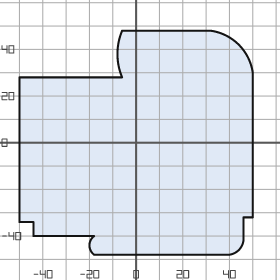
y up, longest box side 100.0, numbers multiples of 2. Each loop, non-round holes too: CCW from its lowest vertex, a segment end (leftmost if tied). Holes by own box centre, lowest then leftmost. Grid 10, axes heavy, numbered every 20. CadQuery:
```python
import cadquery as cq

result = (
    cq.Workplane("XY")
    .moveTo(-18.0, -48.0)
    .lineTo(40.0, -48.0)
    .threePointArc((44.0, -46.0), (46.0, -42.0))
    .lineTo(46.0, -32.0)
    .lineTo(50.0, -32.0)
    .lineTo(50.0, 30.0)
    .threePointArc((44.0, 42.0), (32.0, 48.0))
    .lineTo(-6.0, 48.0)
    .threePointArc((-8.0, 38.0), (-6.0, 28.0))
    .lineTo(-50.0, 28.0)
    .lineTo(-50.0, -34.0)
    .lineTo(-44.0, -34.0)
    .lineTo(-44.0, -40.0)
    .lineTo(-18.0, -40.0)
    .threePointArc((-20.0, -44.0), (-18.0, -48.0))
    .close()
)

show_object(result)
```